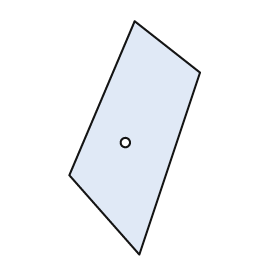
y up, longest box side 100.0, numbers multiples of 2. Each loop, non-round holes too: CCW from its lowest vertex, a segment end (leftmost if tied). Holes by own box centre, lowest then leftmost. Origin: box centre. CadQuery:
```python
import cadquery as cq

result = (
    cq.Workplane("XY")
    .moveTo(2.0, -50.0)
    .lineTo(28.0, 28.0)
    .lineTo(0.0, 50.0)
    .lineTo(-28.0, -16.0)
    .close()
    .moveTo(-4.0, -2.0)
    .circle(2.0)
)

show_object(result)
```